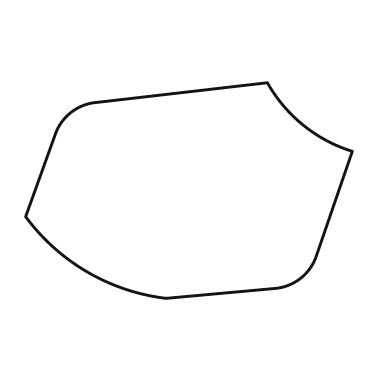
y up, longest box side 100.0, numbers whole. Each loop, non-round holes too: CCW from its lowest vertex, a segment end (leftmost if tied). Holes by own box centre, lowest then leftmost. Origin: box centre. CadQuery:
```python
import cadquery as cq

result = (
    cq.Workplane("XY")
    .moveTo(-7.0, -33.0)
    .lineTo(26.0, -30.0)
    .threePointArc((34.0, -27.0), (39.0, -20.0))
    .lineTo(50.0, 12.0)
    .threePointArc((35.0, 20.0), (24.0, 33.0))
    .lineTo(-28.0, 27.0)
    .threePointArc((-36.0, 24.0), (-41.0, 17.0))
    .lineTo(-50.0, -8.0)
    .threePointArc((-31.0, -25.0), (-7.0, -33.0))
    .close()
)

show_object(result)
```